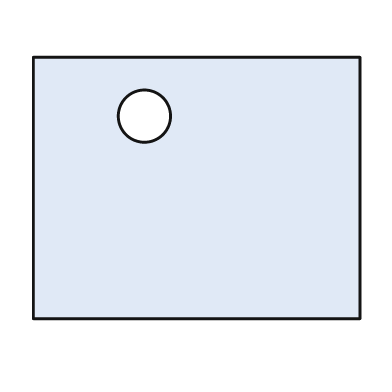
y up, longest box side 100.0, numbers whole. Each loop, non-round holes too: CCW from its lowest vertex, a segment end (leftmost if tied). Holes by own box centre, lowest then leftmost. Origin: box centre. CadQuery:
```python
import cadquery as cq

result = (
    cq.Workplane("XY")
    .moveTo(-50.0, -40.0)
    .lineTo(50.0, -40.0)
    .lineTo(50.0, 40.0)
    .lineTo(-50.0, 40.0)
    .close()
    .moveTo(-16.0, 22.0)
    .circle(8.0)
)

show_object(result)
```